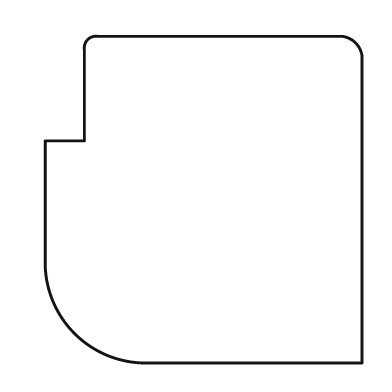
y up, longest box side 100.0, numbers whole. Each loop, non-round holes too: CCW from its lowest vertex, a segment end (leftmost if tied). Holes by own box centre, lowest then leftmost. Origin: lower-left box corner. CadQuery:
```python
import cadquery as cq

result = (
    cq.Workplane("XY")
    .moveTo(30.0, 0.0)
    .lineTo(97.0, 0.0)
    .lineTo(97.0, 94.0)
    .threePointArc((95.0, 98.0), (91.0, 100.0))
    .lineTo(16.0, 100.0)
    .threePointArc((13.0, 99.0), (12.0, 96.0))
    .lineTo(12.0, 68.0)
    .lineTo(0.0, 68.0)
    .lineTo(0.0, 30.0)
    .threePointArc((9.0, 9.0), (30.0, 0.0))
    .close()
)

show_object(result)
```